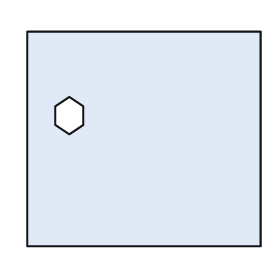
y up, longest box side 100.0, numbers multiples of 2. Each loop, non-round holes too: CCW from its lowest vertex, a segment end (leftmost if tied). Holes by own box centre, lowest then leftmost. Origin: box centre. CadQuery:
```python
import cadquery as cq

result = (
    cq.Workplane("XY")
    .moveTo(-50.0, -46.0)
    .lineTo(50.0, -46.0)
    .lineTo(50.0, 46.0)
    .lineTo(-50.0, 46.0)
    .close()
    .moveTo(-32.0, 2.0)
    .lineTo(-26.0, 6.0)
    .lineTo(-26.0, 14.0)
    .lineTo(-32.0, 18.0)
    .lineTo(-38.0, 14.0)
    .lineTo(-38.0, 6.0)
    .close()
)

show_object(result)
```